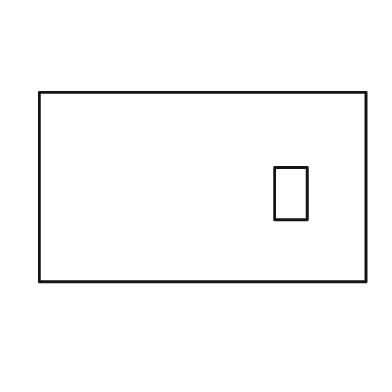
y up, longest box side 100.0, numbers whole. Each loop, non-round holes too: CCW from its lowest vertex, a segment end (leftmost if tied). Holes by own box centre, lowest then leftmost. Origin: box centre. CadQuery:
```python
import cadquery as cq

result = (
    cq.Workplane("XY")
    .moveTo(-50.0, -29.0)
    .lineTo(50.0, -29.0)
    .lineTo(50.0, 29.0)
    .lineTo(-50.0, 29.0)
    .close()
    .moveTo(22.0, -10.0)
    .lineTo(32.0, -10.0)
    .lineTo(32.0, 6.0)
    .lineTo(22.0, 6.0)
    .close()
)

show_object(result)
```